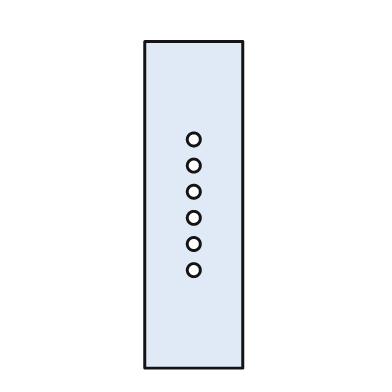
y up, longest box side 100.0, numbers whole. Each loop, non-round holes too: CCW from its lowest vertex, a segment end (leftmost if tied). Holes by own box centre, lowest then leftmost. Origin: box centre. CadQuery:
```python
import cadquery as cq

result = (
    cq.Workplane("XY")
    .moveTo(-15.0, -50.0)
    .lineTo(15.0, -50.0)
    .lineTo(15.0, 50.0)
    .lineTo(-15.0, 50.0)
    .close()
    .moveTo(0.0, -20.0)
    .circle(2.0)
    .moveTo(0.0, -12.0)
    .circle(2.0)
    .moveTo(0.0, -4.0)
    .circle(2.0)
    .moveTo(0.0, 4.0)
    .circle(2.0)
    .moveTo(0.0, 12.0)
    .circle(2.0)
    .moveTo(0.0, 20.0)
    .circle(2.0)
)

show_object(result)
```